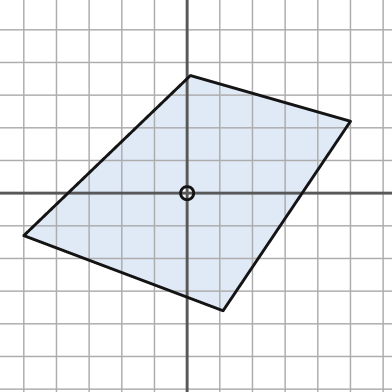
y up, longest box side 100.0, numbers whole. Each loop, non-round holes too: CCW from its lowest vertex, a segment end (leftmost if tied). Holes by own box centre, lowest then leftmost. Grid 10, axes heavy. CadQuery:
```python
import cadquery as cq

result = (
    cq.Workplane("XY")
    .moveTo(11.0, -36.0)
    .lineTo(50.0, 22.0)
    .lineTo(1.0, 36.0)
    .lineTo(-50.0, -13.0)
    .close()
    .moveTo(0.0, 0.0)
    .circle(2.0)
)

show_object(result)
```